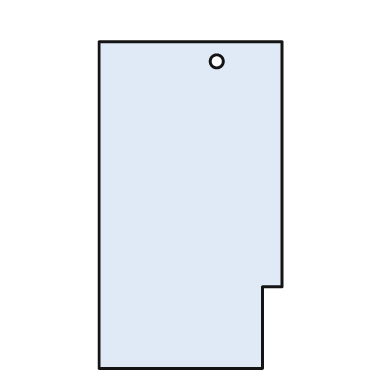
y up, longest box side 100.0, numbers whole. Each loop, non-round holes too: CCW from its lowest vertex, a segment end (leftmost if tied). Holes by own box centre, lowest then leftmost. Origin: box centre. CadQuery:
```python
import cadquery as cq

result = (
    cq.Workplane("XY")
    .moveTo(-28.0, -50.0)
    .lineTo(22.0, -50.0)
    .lineTo(22.0, -25.0)
    .lineTo(28.0, -25.0)
    .lineTo(28.0, 50.0)
    .lineTo(-28.0, 50.0)
    .close()
    .moveTo(8.0, 44.0)
    .circle(2.0)
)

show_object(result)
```